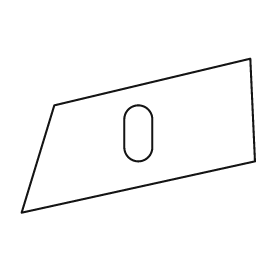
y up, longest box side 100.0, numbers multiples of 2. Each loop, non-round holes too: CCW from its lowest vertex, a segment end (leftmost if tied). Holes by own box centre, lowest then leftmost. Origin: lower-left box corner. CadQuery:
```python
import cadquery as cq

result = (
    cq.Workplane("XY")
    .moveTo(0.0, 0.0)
    .lineTo(100.0, 22.0)
    .lineTo(98.0, 66.0)
    .lineTo(14.0, 46.0)
    .close()
    .moveTo(44.0, 28.0)
    .threePointArc((50.0, 22.0), (56.0, 28.0))
    .lineTo(56.0, 40.0)
    .threePointArc((50.0, 46.0), (44.0, 40.0))
    .close()
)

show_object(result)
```